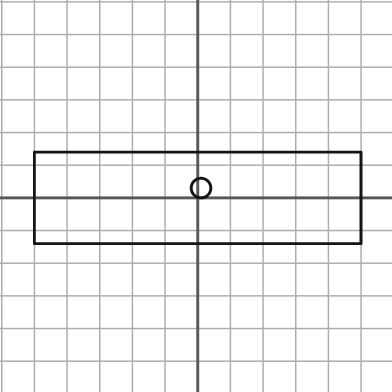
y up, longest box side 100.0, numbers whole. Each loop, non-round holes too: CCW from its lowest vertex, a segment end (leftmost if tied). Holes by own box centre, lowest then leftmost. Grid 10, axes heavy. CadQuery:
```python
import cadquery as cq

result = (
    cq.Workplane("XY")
    .moveTo(-50.0, -14.0)
    .lineTo(50.0, -14.0)
    .lineTo(50.0, 14.0)
    .lineTo(-50.0, 14.0)
    .close()
    .moveTo(1.0, 3.0)
    .circle(3.0)
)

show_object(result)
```